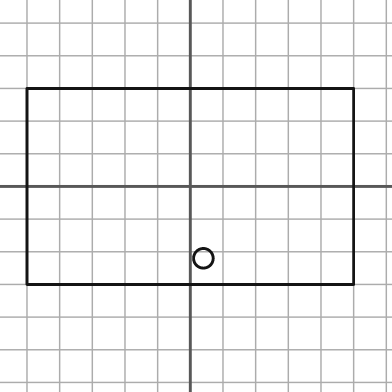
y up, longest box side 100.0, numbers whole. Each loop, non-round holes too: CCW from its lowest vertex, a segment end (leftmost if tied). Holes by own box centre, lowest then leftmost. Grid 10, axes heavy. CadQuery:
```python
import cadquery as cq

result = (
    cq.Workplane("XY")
    .moveTo(-50.0, -30.0)
    .lineTo(50.0, -30.0)
    .lineTo(50.0, 30.0)
    .lineTo(-50.0, 30.0)
    .close()
    .moveTo(4.0, -22.0)
    .circle(3.0)
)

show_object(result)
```